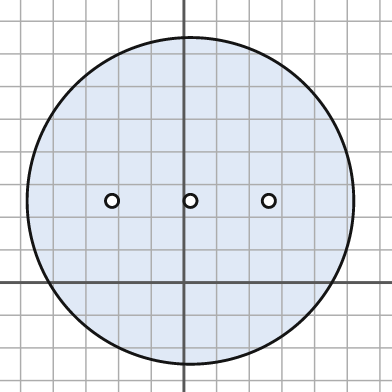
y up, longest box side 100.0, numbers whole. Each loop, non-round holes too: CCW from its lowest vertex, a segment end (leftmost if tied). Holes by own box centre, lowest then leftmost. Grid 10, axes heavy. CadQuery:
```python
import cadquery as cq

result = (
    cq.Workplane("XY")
    .moveTo(2.0, 25.0)
    .circle(50.0)
    .moveTo(-22.0, 25.0)
    .circle(2.0)
    .moveTo(2.0, 25.0)
    .circle(2.0)
    .moveTo(26.0, 25.0)
    .circle(2.0)
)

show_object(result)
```